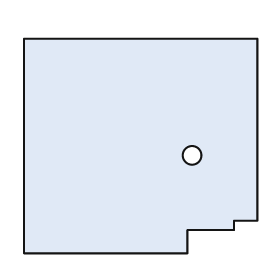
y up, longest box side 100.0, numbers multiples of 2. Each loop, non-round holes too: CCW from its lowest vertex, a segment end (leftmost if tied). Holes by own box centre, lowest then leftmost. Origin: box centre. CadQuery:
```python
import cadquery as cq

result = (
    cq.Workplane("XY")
    .moveTo(-50.0, -46.0)
    .lineTo(20.0, -46.0)
    .lineTo(20.0, -36.0)
    .lineTo(40.0, -36.0)
    .lineTo(40.0, -32.0)
    .lineTo(50.0, -32.0)
    .lineTo(50.0, 46.0)
    .lineTo(-50.0, 46.0)
    .close()
    .moveTo(22.0, -4.0)
    .circle(4.0)
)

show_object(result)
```